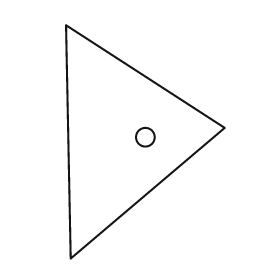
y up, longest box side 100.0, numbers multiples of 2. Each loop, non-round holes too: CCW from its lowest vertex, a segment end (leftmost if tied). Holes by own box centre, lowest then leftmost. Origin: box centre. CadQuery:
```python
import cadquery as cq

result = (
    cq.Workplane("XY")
    .moveTo(-32.0, -50.0)
    .lineTo(34.0, 6.0)
    .lineTo(-34.0, 50.0)
    .close()
    .moveTo(0.0, 2.0)
    .circle(4.0)
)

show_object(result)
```